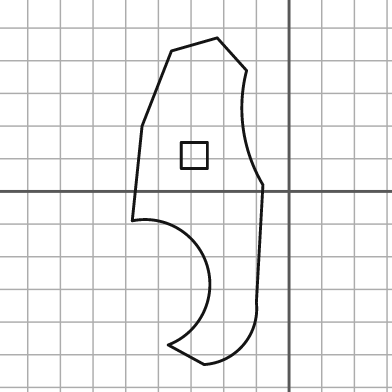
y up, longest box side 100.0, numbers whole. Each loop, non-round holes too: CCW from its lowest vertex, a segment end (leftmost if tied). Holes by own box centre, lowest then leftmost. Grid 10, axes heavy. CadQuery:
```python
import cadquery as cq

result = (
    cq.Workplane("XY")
    .moveTo(-26.0, -53.0)
    .threePointArc((-14.0, -47.0), (-10.0, -34.0))
    .lineTo(-8.0, 2.0)
    .threePointArc((-14.0, 19.0), (-13.0, 37.0))
    .lineTo(-22.0, 47.0)
    .lineTo(-36.0, 43.0)
    .lineTo(-45.0, 20.0)
    .lineTo(-48.0, -9.0)
    .threePointArc((-25.0, -23.0), (-37.0, -47.0))
    .close()
    .moveTo(-33.0, 7.0)
    .lineTo(-25.0, 7.0)
    .lineTo(-25.0, 15.0)
    .lineTo(-33.0, 15.0)
    .close()
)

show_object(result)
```